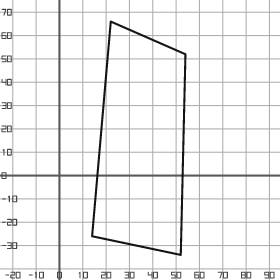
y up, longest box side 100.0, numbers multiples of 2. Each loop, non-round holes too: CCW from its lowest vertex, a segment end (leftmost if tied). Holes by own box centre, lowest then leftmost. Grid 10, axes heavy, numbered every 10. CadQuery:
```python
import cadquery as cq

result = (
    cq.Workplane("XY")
    .moveTo(52.0, -34.0)
    .lineTo(54.0, 52.0)
    .lineTo(22.0, 66.0)
    .lineTo(14.0, -26.0)
    .close()
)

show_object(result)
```